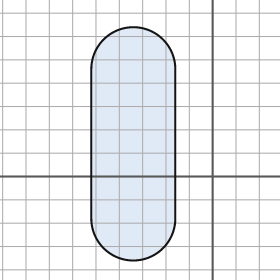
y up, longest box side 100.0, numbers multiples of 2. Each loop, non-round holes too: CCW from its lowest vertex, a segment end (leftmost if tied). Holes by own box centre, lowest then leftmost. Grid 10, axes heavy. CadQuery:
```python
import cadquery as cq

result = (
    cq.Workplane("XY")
    .moveTo(-52.0, -18.0)
    .threePointArc((-34.0, -36.0), (-16.0, -18.0))
    .lineTo(-16.0, 46.0)
    .threePointArc((-34.0, 64.0), (-52.0, 46.0))
    .close()
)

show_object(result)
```